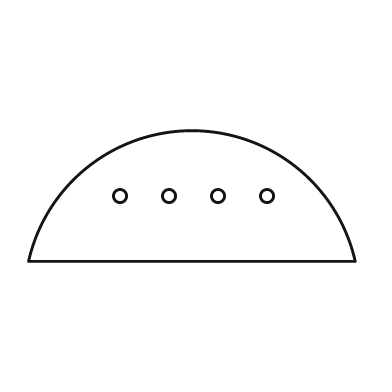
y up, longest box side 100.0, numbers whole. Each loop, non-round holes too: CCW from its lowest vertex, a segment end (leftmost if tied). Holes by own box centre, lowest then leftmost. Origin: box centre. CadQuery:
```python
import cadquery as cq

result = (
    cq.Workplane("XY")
    .moveTo(-50.0, -20.0)
    .lineTo(50.0, -20.0)
    .threePointArc((0.0, 20.0), (-50.0, -20.0))
    .close()
    .moveTo(-22.0, 0.0)
    .circle(2.0)
    .moveTo(-7.0, 0.0)
    .circle(2.0)
    .moveTo(8.0, 0.0)
    .circle(2.0)
    .moveTo(23.0, 0.0)
    .circle(2.0)
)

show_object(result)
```